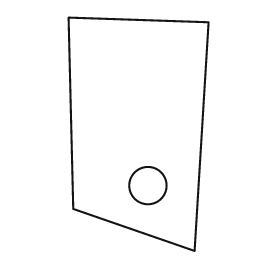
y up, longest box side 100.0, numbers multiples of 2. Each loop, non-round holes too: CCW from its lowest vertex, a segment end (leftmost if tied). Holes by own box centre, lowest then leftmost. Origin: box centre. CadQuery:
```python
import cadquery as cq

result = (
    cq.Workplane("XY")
    .moveTo(24.0, -50.0)
    .lineTo(30.0, 48.0)
    .lineTo(-30.0, 50.0)
    .lineTo(-28.0, -32.0)
    .close()
    .moveTo(4.0, -22.0)
    .circle(8.0)
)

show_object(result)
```